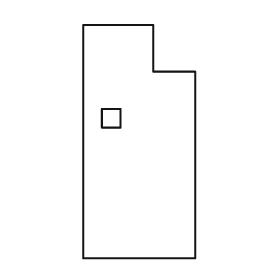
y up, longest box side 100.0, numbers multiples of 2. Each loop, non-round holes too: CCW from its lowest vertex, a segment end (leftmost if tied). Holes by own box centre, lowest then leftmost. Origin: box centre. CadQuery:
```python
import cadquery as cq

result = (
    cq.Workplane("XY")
    .moveTo(-24.0, -50.0)
    .lineTo(24.0, -50.0)
    .lineTo(24.0, 30.0)
    .lineTo(6.0, 30.0)
    .lineTo(6.0, 50.0)
    .lineTo(-24.0, 50.0)
    .close()
    .moveTo(-16.0, 6.0)
    .lineTo(-8.0, 6.0)
    .lineTo(-8.0, 14.0)
    .lineTo(-16.0, 14.0)
    .close()
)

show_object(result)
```